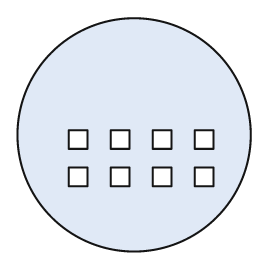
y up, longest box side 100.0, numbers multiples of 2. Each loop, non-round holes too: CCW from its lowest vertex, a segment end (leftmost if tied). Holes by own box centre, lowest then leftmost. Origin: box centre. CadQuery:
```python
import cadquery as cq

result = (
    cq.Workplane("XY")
    .moveTo(0.0, 0.0)
    .circle(50.0)
    .moveTo(-28.0, -22.0)
    .lineTo(-20.0, -22.0)
    .lineTo(-20.0, -14.0)
    .lineTo(-28.0, -14.0)
    .close()
    .moveTo(-10.0, -22.0)
    .lineTo(-2.0, -22.0)
    .lineTo(-2.0, -14.0)
    .lineTo(-10.0, -14.0)
    .close()
    .moveTo(8.0, -22.0)
    .lineTo(16.0, -22.0)
    .lineTo(16.0, -14.0)
    .lineTo(8.0, -14.0)
    .close()
    .moveTo(26.0, -22.0)
    .lineTo(34.0, -22.0)
    .lineTo(34.0, -14.0)
    .lineTo(26.0, -14.0)
    .close()
    .moveTo(-28.0, -6.0)
    .lineTo(-20.0, -6.0)
    .lineTo(-20.0, 2.0)
    .lineTo(-28.0, 2.0)
    .close()
    .moveTo(-10.0, -6.0)
    .lineTo(-2.0, -6.0)
    .lineTo(-2.0, 2.0)
    .lineTo(-10.0, 2.0)
    .close()
    .moveTo(8.0, -6.0)
    .lineTo(16.0, -6.0)
    .lineTo(16.0, 2.0)
    .lineTo(8.0, 2.0)
    .close()
    .moveTo(26.0, -6.0)
    .lineTo(34.0, -6.0)
    .lineTo(34.0, 2.0)
    .lineTo(26.0, 2.0)
    .close()
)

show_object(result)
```